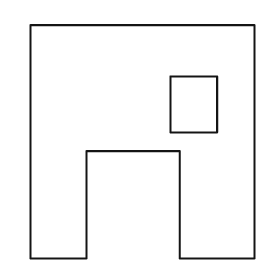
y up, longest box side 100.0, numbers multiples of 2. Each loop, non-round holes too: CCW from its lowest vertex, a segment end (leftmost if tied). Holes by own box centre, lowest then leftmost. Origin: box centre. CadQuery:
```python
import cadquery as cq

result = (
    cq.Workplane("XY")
    .moveTo(-48.0, -50.0)
    .lineTo(-24.0, -50.0)
    .lineTo(-24.0, -4.0)
    .lineTo(16.0, -4.0)
    .lineTo(16.0, -50.0)
    .lineTo(48.0, -50.0)
    .lineTo(48.0, 50.0)
    .lineTo(-48.0, 50.0)
    .close()
    .moveTo(12.0, 4.0)
    .lineTo(32.0, 4.0)
    .lineTo(32.0, 28.0)
    .lineTo(12.0, 28.0)
    .close()
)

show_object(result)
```